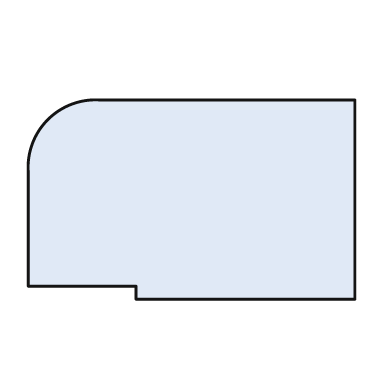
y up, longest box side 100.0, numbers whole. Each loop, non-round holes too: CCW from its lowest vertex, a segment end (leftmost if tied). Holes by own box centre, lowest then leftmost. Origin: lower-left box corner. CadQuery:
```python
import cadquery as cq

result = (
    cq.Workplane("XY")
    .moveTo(33.0, 0.0)
    .lineTo(100.0, 0.0)
    .lineTo(100.0, 61.0)
    .lineTo(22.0, 61.0)
    .threePointArc((6.0, 55.0), (0.0, 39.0))
    .lineTo(0.0, 4.0)
    .lineTo(33.0, 4.0)
    .close()
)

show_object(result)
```